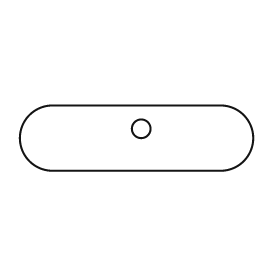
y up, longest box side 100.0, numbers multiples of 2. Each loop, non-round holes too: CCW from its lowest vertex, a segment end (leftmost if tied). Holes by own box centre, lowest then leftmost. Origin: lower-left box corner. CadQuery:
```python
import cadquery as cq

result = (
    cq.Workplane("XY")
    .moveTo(14.0, 0.0)
    .lineTo(86.0, 0.0)
    .threePointArc((100.0, 14.0), (86.0, 28.0))
    .lineTo(14.0, 28.0)
    .threePointArc((0.0, 14.0), (14.0, 0.0))
    .close()
    .moveTo(52.0, 18.0)
    .circle(4.0)
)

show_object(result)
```